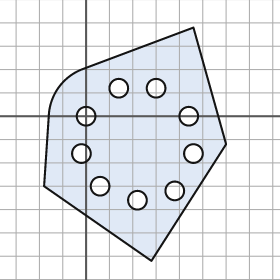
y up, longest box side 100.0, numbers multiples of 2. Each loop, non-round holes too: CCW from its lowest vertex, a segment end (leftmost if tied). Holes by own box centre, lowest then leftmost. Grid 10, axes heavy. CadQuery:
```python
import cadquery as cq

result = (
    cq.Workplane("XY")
    .moveTo(28.0, -62.0)
    .lineTo(60.0, -12.0)
    .lineTo(46.0, 38.0)
    .lineTo(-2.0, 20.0)
    .threePointArc((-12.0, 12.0), (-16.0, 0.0))
    .lineTo(-18.0, -30.0)
    .close()
    .moveTo(22.0, -36.0)
    .circle(4.0)
    .moveTo(38.0, -32.0)
    .circle(4.0)
    .moveTo(6.0, -30.0)
    .circle(4.0)
    .moveTo(-2.0, -16.0)
    .circle(4.0)
    .moveTo(46.0, -16.0)
    .circle(4.0)
    .moveTo(0.0, 0.0)
    .circle(4.0)
    .moveTo(44.0, 0.0)
    .circle(4.0)
    .moveTo(14.0, 12.0)
    .circle(4.0)
    .moveTo(30.0, 12.0)
    .circle(4.0)
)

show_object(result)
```